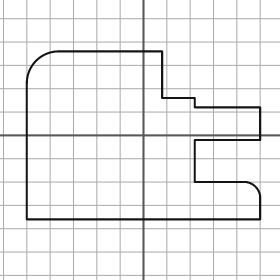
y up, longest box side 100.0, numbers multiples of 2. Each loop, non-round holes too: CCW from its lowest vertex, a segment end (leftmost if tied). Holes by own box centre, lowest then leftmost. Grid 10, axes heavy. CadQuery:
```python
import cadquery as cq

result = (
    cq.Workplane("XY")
    .moveTo(-50.0, -36.0)
    .lineTo(50.0, -36.0)
    .lineTo(50.0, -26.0)
    .threePointArc((48.0, -22.0), (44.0, -20.0))
    .lineTo(22.0, -20.0)
    .lineTo(22.0, -2.0)
    .lineTo(50.0, -2.0)
    .lineTo(50.0, 12.0)
    .lineTo(22.0, 12.0)
    .lineTo(22.0, 16.0)
    .lineTo(8.0, 16.0)
    .lineTo(8.0, 36.0)
    .lineTo(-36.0, 36.0)
    .threePointArc((-46.0, 32.0), (-50.0, 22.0))
    .close()
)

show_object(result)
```